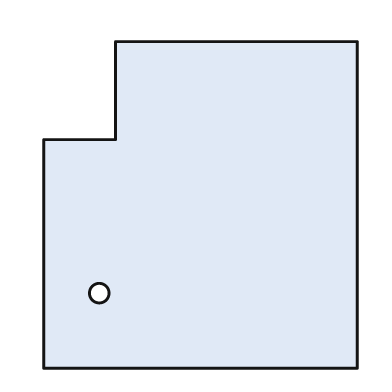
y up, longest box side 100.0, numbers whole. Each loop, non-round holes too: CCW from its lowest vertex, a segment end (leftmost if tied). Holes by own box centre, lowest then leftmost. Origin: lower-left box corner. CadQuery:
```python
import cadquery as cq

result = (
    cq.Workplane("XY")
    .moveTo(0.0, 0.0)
    .lineTo(96.0, 0.0)
    .lineTo(96.0, 100.0)
    .lineTo(22.0, 100.0)
    .lineTo(22.0, 70.0)
    .lineTo(0.0, 70.0)
    .close()
    .moveTo(17.0, 23.0)
    .circle(3.0)
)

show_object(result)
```